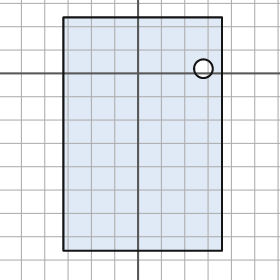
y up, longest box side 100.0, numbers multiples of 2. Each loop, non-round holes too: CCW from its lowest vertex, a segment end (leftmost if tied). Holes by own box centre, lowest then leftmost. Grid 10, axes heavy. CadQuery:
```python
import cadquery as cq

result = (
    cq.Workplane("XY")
    .moveTo(-32.0, -76.0)
    .lineTo(36.0, -76.0)
    .lineTo(36.0, 24.0)
    .lineTo(-32.0, 24.0)
    .close()
    .moveTo(28.0, 2.0)
    .circle(4.0)
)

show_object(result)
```